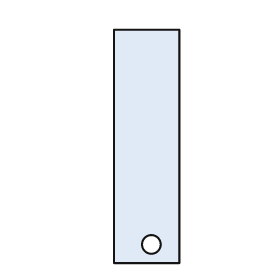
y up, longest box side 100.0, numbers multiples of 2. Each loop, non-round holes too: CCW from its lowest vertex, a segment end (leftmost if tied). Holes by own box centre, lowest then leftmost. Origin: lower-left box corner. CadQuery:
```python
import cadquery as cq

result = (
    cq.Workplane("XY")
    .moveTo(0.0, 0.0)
    .lineTo(28.0, 0.0)
    .lineTo(28.0, 100.0)
    .lineTo(0.0, 100.0)
    .close()
    .moveTo(16.0, 8.0)
    .circle(4.0)
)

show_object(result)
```